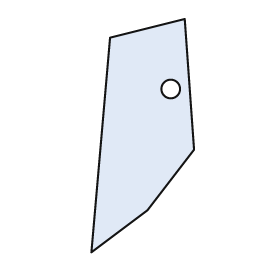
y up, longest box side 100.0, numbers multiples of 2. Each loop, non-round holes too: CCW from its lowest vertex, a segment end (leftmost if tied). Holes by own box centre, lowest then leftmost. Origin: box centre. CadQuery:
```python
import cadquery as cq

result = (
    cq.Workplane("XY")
    .moveTo(-22.0, -50.0)
    .lineTo(2.0, -32.0)
    .lineTo(22.0, -6.0)
    .lineTo(18.0, 50.0)
    .lineTo(-14.0, 42.0)
    .close()
    .moveTo(12.0, 20.0)
    .circle(4.0)
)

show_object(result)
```